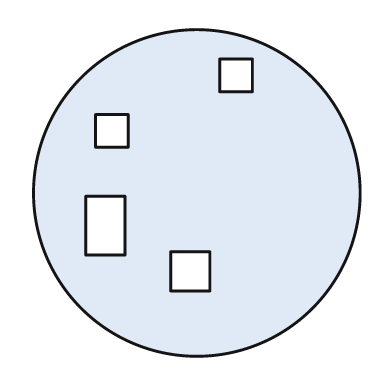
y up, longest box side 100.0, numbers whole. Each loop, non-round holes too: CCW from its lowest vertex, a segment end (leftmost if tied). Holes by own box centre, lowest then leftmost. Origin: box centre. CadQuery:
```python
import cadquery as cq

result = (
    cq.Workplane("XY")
    .moveTo(0.0, 0.0)
    .circle(50.0)
    .moveTo(-8.0, -30.0)
    .lineTo(4.0, -30.0)
    .lineTo(4.0, -18.0)
    .lineTo(-8.0, -18.0)
    .close()
    .moveTo(-34.0, -19.0)
    .lineTo(-22.0, -19.0)
    .lineTo(-22.0, -1.0)
    .lineTo(-34.0, -1.0)
    .close()
    .moveTo(-31.0, 14.0)
    .lineTo(-21.0, 14.0)
    .lineTo(-21.0, 24.0)
    .lineTo(-31.0, 24.0)
    .close()
    .moveTo(7.0, 31.0)
    .lineTo(17.0, 31.0)
    .lineTo(17.0, 41.0)
    .lineTo(7.0, 41.0)
    .close()
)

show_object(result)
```